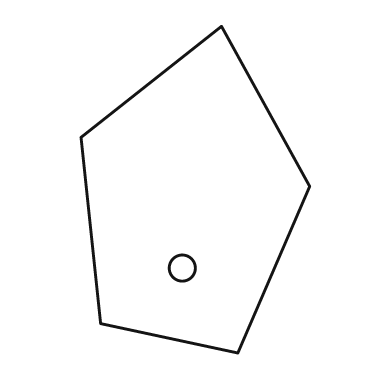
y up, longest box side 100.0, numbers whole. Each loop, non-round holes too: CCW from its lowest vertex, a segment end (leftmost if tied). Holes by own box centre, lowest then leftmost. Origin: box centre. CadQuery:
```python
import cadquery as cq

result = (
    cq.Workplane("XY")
    .moveTo(13.0, -50.0)
    .lineTo(35.0, 1.0)
    .lineTo(8.0, 50.0)
    .lineTo(-35.0, 16.0)
    .lineTo(-29.0, -41.0)
    .close()
    .moveTo(-4.0, -24.0)
    .circle(4.0)
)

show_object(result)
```